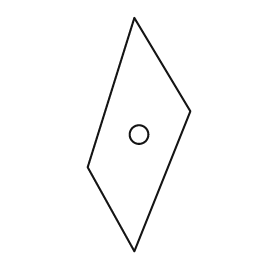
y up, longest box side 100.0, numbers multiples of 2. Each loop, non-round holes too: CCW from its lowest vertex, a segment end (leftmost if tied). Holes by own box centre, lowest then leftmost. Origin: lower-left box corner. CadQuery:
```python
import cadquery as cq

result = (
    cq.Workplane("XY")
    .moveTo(20.0, 0.0)
    .lineTo(44.0, 60.0)
    .lineTo(20.0, 100.0)
    .lineTo(0.0, 36.0)
    .close()
    .moveTo(22.0, 50.0)
    .circle(4.0)
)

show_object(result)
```